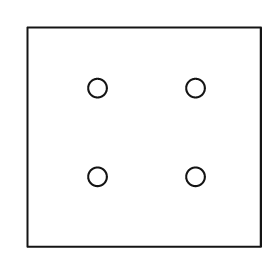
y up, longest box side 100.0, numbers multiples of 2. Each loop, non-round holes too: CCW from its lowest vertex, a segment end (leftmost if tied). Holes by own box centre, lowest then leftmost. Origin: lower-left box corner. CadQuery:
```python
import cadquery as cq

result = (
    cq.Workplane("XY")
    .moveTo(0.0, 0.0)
    .lineTo(100.0, 0.0)
    .lineTo(100.0, 94.0)
    .lineTo(0.0, 94.0)
    .close()
    .moveTo(30.0, 30.0)
    .circle(4.0)
    .moveTo(72.0, 30.0)
    .circle(4.0)
    .moveTo(30.0, 68.0)
    .circle(4.0)
    .moveTo(72.0, 68.0)
    .circle(4.0)
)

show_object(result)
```